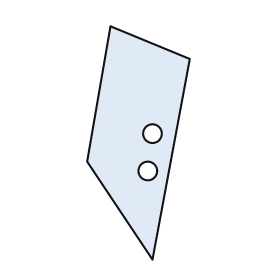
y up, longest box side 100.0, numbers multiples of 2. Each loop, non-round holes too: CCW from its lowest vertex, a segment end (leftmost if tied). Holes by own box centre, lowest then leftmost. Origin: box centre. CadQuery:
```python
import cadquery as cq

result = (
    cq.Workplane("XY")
    .moveTo(6.0, -50.0)
    .lineTo(22.0, 36.0)
    .lineTo(-12.0, 50.0)
    .lineTo(-22.0, -8.0)
    .close()
    .moveTo(4.0, -12.0)
    .circle(4.0)
    .moveTo(6.0, 4.0)
    .circle(4.0)
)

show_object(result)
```